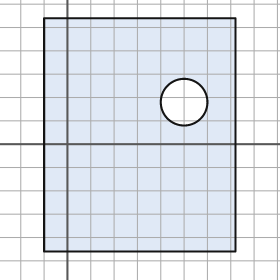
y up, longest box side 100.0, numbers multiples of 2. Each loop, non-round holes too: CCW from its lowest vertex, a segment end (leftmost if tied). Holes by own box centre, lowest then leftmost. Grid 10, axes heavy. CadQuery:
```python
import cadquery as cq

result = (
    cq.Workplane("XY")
    .moveTo(-10.0, -46.0)
    .lineTo(72.0, -46.0)
    .lineTo(72.0, 54.0)
    .lineTo(-10.0, 54.0)
    .close()
    .moveTo(50.0, 18.0)
    .circle(10.0)
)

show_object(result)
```